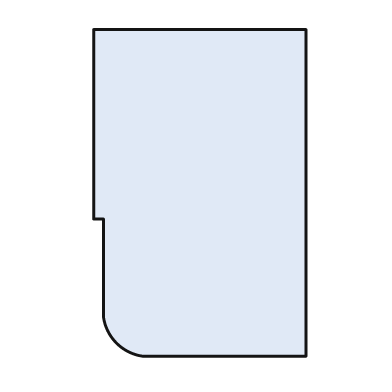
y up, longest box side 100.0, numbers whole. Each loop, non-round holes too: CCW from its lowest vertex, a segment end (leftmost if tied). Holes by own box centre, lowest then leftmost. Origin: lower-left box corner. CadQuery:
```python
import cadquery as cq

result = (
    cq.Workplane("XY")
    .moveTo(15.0, 0.0)
    .lineTo(65.0, 0.0)
    .lineTo(65.0, 100.0)
    .lineTo(0.0, 100.0)
    .lineTo(0.0, 42.0)
    .lineTo(3.0, 42.0)
    .lineTo(3.0, 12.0)
    .threePointArc((7.0, 4.0), (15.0, 0.0))
    .close()
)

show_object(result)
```